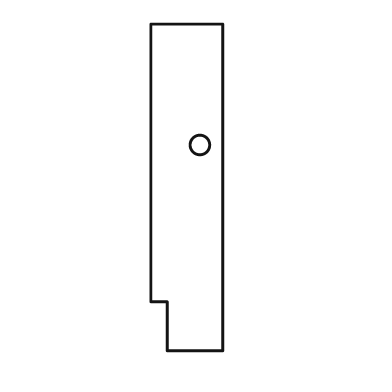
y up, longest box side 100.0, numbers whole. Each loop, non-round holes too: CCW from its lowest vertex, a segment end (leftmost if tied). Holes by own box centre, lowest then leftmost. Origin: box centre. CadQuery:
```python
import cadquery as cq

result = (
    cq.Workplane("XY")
    .moveTo(-6.0, -50.0)
    .lineTo(11.0, -50.0)
    .lineTo(11.0, 50.0)
    .lineTo(-11.0, 50.0)
    .lineTo(-11.0, -35.0)
    .lineTo(-6.0, -35.0)
    .close()
    .moveTo(4.0, 13.0)
    .circle(3.0)
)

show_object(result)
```